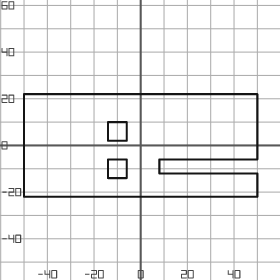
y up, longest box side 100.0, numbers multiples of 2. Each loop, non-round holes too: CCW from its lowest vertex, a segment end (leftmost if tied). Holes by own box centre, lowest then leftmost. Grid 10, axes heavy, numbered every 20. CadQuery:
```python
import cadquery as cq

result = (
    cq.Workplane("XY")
    .moveTo(-50.0, -22.0)
    .lineTo(50.0, -22.0)
    .lineTo(50.0, -12.0)
    .lineTo(8.0, -12.0)
    .lineTo(8.0, -6.0)
    .lineTo(50.0, -6.0)
    .lineTo(50.0, 22.0)
    .lineTo(-50.0, 22.0)
    .close()
    .moveTo(-14.0, -14.0)
    .lineTo(-6.0, -14.0)
    .lineTo(-6.0, -6.0)
    .lineTo(-14.0, -6.0)
    .close()
    .moveTo(-14.0, 2.0)
    .lineTo(-6.0, 2.0)
    .lineTo(-6.0, 10.0)
    .lineTo(-14.0, 10.0)
    .close()
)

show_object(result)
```